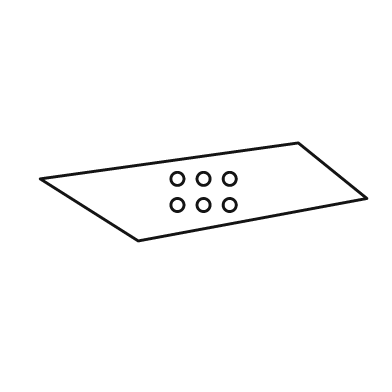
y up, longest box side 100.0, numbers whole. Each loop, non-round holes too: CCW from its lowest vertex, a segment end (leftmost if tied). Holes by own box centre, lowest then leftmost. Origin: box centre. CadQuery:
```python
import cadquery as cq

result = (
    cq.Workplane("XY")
    .moveTo(-20.0, -15.0)
    .lineTo(50.0, -2.0)
    .lineTo(29.0, 15.0)
    .lineTo(-50.0, 4.0)
    .close()
    .moveTo(-8.0, -4.0)
    .circle(2.0)
    .moveTo(0.0, -4.0)
    .circle(2.0)
    .moveTo(8.0, -4.0)
    .circle(2.0)
    .moveTo(-8.0, 4.0)
    .circle(2.0)
    .moveTo(0.0, 4.0)
    .circle(2.0)
    .moveTo(8.0, 4.0)
    .circle(2.0)
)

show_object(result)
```